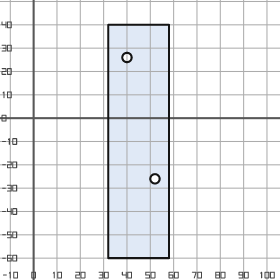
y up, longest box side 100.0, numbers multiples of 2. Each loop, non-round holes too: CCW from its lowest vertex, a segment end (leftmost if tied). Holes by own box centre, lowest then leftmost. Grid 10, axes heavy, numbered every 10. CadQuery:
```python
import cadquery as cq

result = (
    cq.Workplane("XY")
    .moveTo(32.0, -60.0)
    .lineTo(58.0, -60.0)
    .lineTo(58.0, 40.0)
    .lineTo(32.0, 40.0)
    .close()
    .moveTo(52.0, -26.0)
    .circle(2.0)
    .moveTo(40.0, 26.0)
    .circle(2.0)
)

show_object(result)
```